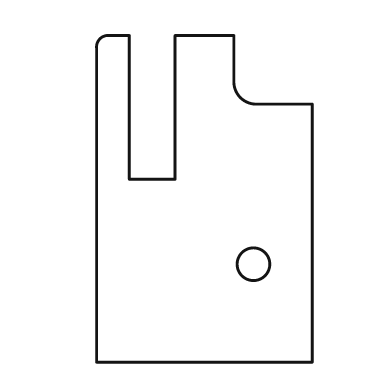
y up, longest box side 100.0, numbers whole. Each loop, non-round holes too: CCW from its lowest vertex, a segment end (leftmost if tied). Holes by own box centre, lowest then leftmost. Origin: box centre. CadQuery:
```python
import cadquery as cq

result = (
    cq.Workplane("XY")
    .moveTo(-33.0, -50.0)
    .lineTo(33.0, -50.0)
    .lineTo(33.0, 29.0)
    .lineTo(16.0, 29.0)
    .threePointArc((11.0, 31.0), (9.0, 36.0))
    .lineTo(9.0, 50.0)
    .lineTo(-9.0, 50.0)
    .lineTo(-9.0, 6.0)
    .lineTo(-23.0, 6.0)
    .lineTo(-23.0, 50.0)
    .lineTo(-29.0, 50.0)
    .threePointArc((-32.0, 49.0), (-33.0, 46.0))
    .close()
    .moveTo(15.0, -20.0)
    .circle(5.0)
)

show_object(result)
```